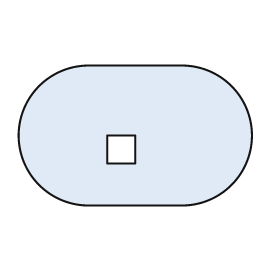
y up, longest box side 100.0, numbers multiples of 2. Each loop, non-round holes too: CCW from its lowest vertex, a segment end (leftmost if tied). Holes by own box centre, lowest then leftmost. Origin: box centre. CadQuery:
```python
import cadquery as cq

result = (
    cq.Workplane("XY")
    .moveTo(-20.0, -30.0)
    .lineTo(20.0, -30.0)
    .threePointArc((50.0, 0.0), (20.0, 30.0))
    .lineTo(-20.0, 30.0)
    .threePointArc((-50.0, 0.0), (-20.0, -30.0))
    .close()
    .moveTo(-12.0, -12.0)
    .lineTo(0.0, -12.0)
    .lineTo(0.0, 0.0)
    .lineTo(-12.0, 0.0)
    .close()
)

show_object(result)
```